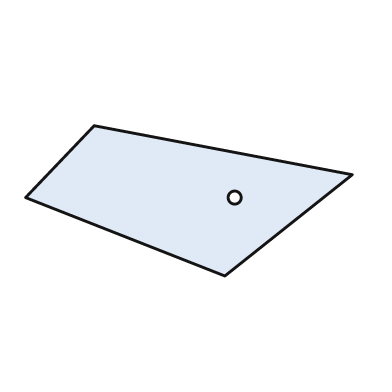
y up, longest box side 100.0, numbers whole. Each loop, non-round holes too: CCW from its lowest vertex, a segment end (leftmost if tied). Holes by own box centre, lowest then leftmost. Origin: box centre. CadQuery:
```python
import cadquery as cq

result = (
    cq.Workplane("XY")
    .moveTo(11.0, -23.0)
    .lineTo(50.0, 8.0)
    .lineTo(-29.0, 23.0)
    .lineTo(-50.0, 1.0)
    .close()
    .moveTo(14.0, 1.0)
    .circle(2.0)
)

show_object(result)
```